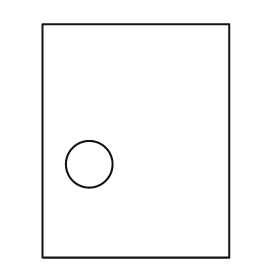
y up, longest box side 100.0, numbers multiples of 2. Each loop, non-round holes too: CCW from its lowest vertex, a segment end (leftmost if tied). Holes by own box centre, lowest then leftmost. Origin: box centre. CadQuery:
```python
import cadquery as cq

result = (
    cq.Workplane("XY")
    .moveTo(-40.0, -50.0)
    .lineTo(40.0, -50.0)
    .lineTo(40.0, 50.0)
    .lineTo(-40.0, 50.0)
    .close()
    .moveTo(-20.0, -10.0)
    .circle(10.0)
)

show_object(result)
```